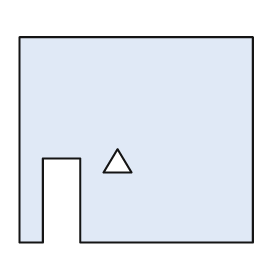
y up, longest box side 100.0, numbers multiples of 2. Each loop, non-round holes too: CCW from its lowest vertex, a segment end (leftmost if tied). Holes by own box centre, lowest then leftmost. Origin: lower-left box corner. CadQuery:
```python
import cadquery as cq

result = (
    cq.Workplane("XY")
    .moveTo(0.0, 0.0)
    .lineTo(10.0, 0.0)
    .lineTo(10.0, 36.0)
    .lineTo(26.0, 36.0)
    .lineTo(26.0, 0.0)
    .lineTo(100.0, 0.0)
    .lineTo(100.0, 88.0)
    .lineTo(0.0, 88.0)
    .close()
    .moveTo(36.0, 30.0)
    .lineTo(48.0, 30.0)
    .lineTo(42.0, 40.0)
    .close()
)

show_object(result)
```